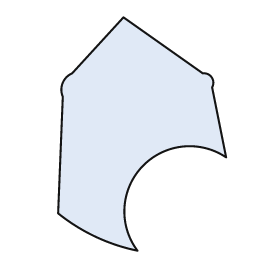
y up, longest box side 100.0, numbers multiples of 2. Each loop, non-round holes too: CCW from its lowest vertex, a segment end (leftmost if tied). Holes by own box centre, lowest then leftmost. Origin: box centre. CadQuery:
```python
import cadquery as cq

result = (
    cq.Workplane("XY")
    .moveTo(-2.0, -50.0)
    .threePointArc((0.0, -14.0), (36.0, -10.0))
    .lineTo(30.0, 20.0)
    .threePointArc((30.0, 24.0), (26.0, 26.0))
    .lineTo(-8.0, 50.0)
    .lineTo(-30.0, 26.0)
    .threePointArc((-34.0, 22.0), (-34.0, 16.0))
    .lineTo(-36.0, -34.0)
    .threePointArc((-20.0, -44.0), (-2.0, -50.0))
    .close()
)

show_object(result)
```